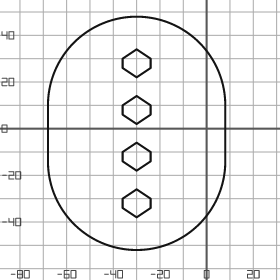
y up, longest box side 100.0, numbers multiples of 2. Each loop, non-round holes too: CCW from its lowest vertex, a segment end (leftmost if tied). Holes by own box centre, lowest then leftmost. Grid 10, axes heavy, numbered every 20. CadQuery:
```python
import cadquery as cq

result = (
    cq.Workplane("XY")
    .moveTo(-68.0, -14.0)
    .threePointArc((-30.0, -52.0), (8.0, -14.0))
    .lineTo(8.0, 10.0)
    .threePointArc((-30.0, 48.0), (-68.0, 10.0))
    .close()
    .moveTo(-30.0, -38.0)
    .lineTo(-24.0, -34.0)
    .lineTo(-24.0, -30.0)
    .lineTo(-30.0, -26.0)
    .lineTo(-36.0, -30.0)
    .lineTo(-36.0, -34.0)
    .close()
    .moveTo(-30.0, -18.0)
    .lineTo(-24.0, -14.0)
    .lineTo(-24.0, -10.0)
    .lineTo(-30.0, -6.0)
    .lineTo(-36.0, -10.0)
    .lineTo(-36.0, -14.0)
    .close()
    .moveTo(-30.0, 2.0)
    .lineTo(-24.0, 6.0)
    .lineTo(-24.0, 10.0)
    .lineTo(-30.0, 14.0)
    .lineTo(-36.0, 10.0)
    .lineTo(-36.0, 6.0)
    .close()
    .moveTo(-30.0, 22.0)
    .lineTo(-24.0, 26.0)
    .lineTo(-24.0, 30.0)
    .lineTo(-30.0, 34.0)
    .lineTo(-36.0, 30.0)
    .lineTo(-36.0, 26.0)
    .close()
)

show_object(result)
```